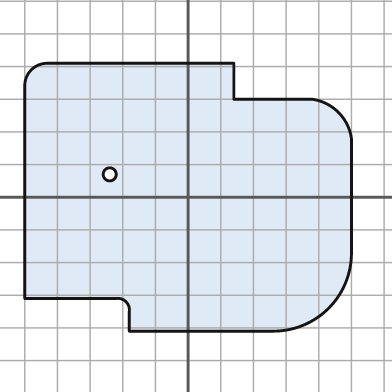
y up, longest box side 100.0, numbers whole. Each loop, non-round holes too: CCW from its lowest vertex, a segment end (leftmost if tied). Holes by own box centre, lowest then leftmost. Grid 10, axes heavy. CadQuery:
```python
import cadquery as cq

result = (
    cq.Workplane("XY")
    .moveTo(-18.0, -41.0)
    .lineTo(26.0, -41.0)
    .threePointArc((43.0, -34.0), (50.0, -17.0))
    .lineTo(50.0, 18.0)
    .threePointArc((46.0, 26.0), (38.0, 30.0))
    .lineTo(14.0, 30.0)
    .lineTo(14.0, 41.0)
    .lineTo(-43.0, 41.0)
    .threePointArc((-48.0, 39.0), (-50.0, 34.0))
    .lineTo(-50.0, -31.0)
    .lineTo(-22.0, -31.0)
    .threePointArc((-19.0, -32.0), (-18.0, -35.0))
    .close()
    .moveTo(-24.0, 7.0)
    .circle(2.0)
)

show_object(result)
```